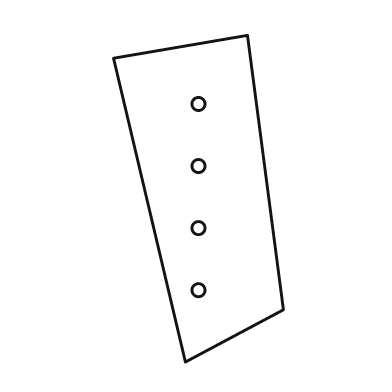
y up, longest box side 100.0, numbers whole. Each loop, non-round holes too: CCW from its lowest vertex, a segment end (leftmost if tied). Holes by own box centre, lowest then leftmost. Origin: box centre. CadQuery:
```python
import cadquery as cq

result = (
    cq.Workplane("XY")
    .moveTo(-4.0, -50.0)
    .lineTo(26.0, -34.0)
    .lineTo(15.0, 50.0)
    .lineTo(-26.0, 43.0)
    .close()
    .moveTo(0.0, -28.0)
    .circle(2.0)
    .moveTo(0.0, -9.0)
    .circle(2.0)
    .moveTo(0.0, 10.0)
    .circle(2.0)
    .moveTo(0.0, 29.0)
    .circle(2.0)
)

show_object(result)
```